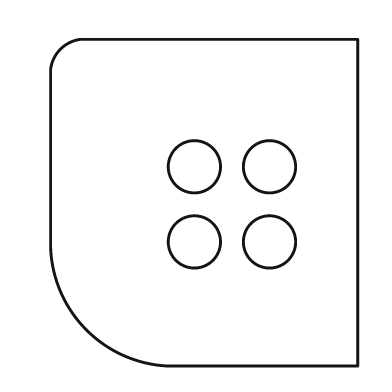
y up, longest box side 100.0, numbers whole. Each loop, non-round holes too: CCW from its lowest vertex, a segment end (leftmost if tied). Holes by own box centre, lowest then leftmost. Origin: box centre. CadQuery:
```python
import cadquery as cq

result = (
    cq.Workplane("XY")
    .moveTo(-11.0, -50.0)
    .lineTo(47.0, -50.0)
    .lineTo(47.0, 50.0)
    .lineTo(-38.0, 50.0)
    .threePointArc((-44.0, 47.0), (-47.0, 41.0))
    .lineTo(-47.0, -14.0)
    .threePointArc((-36.0, -39.0), (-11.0, -50.0))
    .close()
    .moveTo(-3.0, -12.0)
    .circle(8.0)
    .moveTo(20.0, -12.0)
    .circle(8.0)
    .moveTo(-3.0, 11.0)
    .circle(8.0)
    .moveTo(20.0, 11.0)
    .circle(8.0)
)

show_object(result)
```